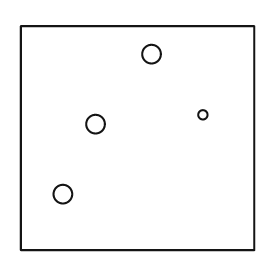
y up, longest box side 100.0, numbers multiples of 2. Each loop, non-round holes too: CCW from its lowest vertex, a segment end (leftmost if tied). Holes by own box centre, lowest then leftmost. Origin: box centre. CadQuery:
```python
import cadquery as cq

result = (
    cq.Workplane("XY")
    .moveTo(-50.0, -48.0)
    .lineTo(50.0, -48.0)
    .lineTo(50.0, 48.0)
    .lineTo(-50.0, 48.0)
    .close()
    .moveTo(-32.0, -24.0)
    .circle(4.0)
    .moveTo(-18.0, 6.0)
    .circle(4.0)
    .moveTo(28.0, 10.0)
    .circle(2.0)
    .moveTo(6.0, 36.0)
    .circle(4.0)
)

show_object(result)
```